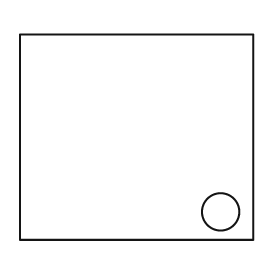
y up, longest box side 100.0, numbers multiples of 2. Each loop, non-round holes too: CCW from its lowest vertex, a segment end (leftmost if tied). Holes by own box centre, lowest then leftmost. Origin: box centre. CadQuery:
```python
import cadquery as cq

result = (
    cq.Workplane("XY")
    .moveTo(-50.0, -44.0)
    .lineTo(50.0, -44.0)
    .lineTo(50.0, 44.0)
    .lineTo(-50.0, 44.0)
    .close()
    .moveTo(36.0, -32.0)
    .circle(8.0)
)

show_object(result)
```